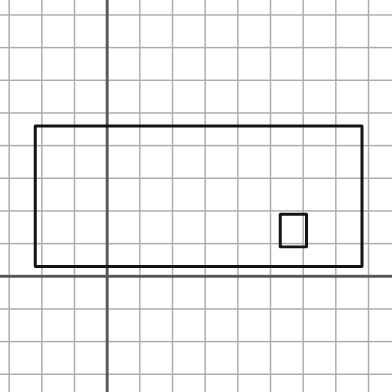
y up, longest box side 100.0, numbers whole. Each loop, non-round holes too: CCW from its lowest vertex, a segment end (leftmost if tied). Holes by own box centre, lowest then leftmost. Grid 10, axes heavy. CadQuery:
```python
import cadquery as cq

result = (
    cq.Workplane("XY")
    .moveTo(-22.0, 3.0)
    .lineTo(78.0, 3.0)
    .lineTo(78.0, 46.0)
    .lineTo(-22.0, 46.0)
    .close()
    .moveTo(53.0, 9.0)
    .lineTo(61.0, 9.0)
    .lineTo(61.0, 19.0)
    .lineTo(53.0, 19.0)
    .close()
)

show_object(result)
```